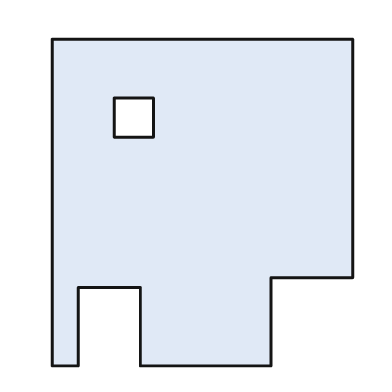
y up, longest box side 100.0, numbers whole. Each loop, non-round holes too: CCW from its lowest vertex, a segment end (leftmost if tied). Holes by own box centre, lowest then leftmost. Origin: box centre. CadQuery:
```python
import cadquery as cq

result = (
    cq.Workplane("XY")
    .moveTo(-46.0, -50.0)
    .lineTo(-38.0, -50.0)
    .lineTo(-38.0, -26.0)
    .lineTo(-19.0, -26.0)
    .lineTo(-19.0, -50.0)
    .lineTo(21.0, -50.0)
    .lineTo(21.0, -23.0)
    .lineTo(46.0, -23.0)
    .lineTo(46.0, 50.0)
    .lineTo(-46.0, 50.0)
    .close()
    .moveTo(-27.0, 20.0)
    .lineTo(-15.0, 20.0)
    .lineTo(-15.0, 32.0)
    .lineTo(-27.0, 32.0)
    .close()
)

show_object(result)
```